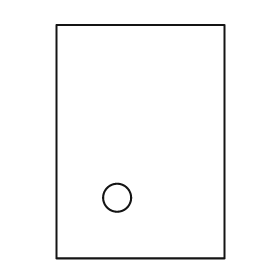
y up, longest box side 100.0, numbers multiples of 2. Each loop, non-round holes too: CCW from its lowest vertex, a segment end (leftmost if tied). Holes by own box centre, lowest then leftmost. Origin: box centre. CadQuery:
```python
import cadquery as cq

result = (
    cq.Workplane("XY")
    .moveTo(-36.0, -50.0)
    .lineTo(36.0, -50.0)
    .lineTo(36.0, 50.0)
    .lineTo(-36.0, 50.0)
    .close()
    .moveTo(-10.0, -24.0)
    .circle(6.0)
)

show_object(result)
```